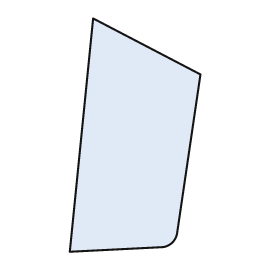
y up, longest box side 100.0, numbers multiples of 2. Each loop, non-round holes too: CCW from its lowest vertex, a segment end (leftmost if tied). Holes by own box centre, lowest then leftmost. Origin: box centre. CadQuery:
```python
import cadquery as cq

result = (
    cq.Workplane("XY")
    .moveTo(-28.0, -50.0)
    .lineTo(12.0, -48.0)
    .threePointArc((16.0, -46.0), (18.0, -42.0))
    .lineTo(28.0, 26.0)
    .lineTo(-18.0, 50.0)
    .close()
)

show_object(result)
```